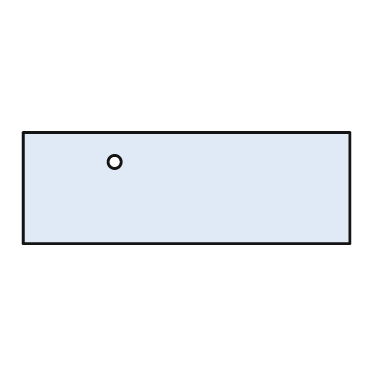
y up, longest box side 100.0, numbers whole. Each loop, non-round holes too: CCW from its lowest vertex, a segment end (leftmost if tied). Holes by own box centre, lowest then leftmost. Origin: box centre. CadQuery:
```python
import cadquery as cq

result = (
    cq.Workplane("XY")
    .moveTo(-50.0, -17.0)
    .lineTo(50.0, -17.0)
    .lineTo(50.0, 17.0)
    .lineTo(-50.0, 17.0)
    .close()
    .moveTo(-22.0, 8.0)
    .circle(2.0)
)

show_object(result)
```